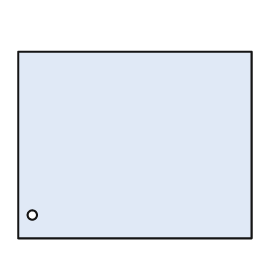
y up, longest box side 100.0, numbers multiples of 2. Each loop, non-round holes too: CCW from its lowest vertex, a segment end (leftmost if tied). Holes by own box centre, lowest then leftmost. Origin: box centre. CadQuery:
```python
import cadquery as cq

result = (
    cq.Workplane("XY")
    .moveTo(-50.0, -40.0)
    .lineTo(50.0, -40.0)
    .lineTo(50.0, 40.0)
    .lineTo(-50.0, 40.0)
    .close()
    .moveTo(-44.0, -30.0)
    .circle(2.0)
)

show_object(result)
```